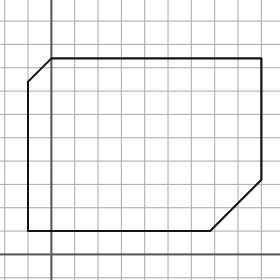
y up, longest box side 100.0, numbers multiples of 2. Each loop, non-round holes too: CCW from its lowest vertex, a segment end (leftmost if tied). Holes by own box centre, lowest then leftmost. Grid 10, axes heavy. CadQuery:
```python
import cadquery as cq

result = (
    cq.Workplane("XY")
    .moveTo(-10.0, 10.0)
    .lineTo(68.0, 10.0)
    .lineTo(90.0, 32.0)
    .lineTo(90.0, 84.0)
    .lineTo(0.0, 84.0)
    .lineTo(-10.0, 74.0)
    .close()
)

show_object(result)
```